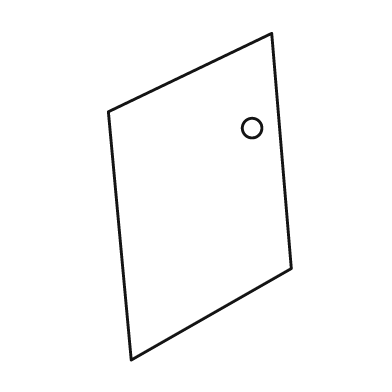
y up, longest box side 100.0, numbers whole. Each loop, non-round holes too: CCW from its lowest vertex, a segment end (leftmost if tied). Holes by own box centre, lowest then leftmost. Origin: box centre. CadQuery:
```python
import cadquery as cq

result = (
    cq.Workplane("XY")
    .moveTo(-21.0, -50.0)
    .lineTo(28.0, -22.0)
    .lineTo(22.0, 50.0)
    .lineTo(-28.0, 26.0)
    .close()
    .moveTo(16.0, 21.0)
    .circle(3.0)
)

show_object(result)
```